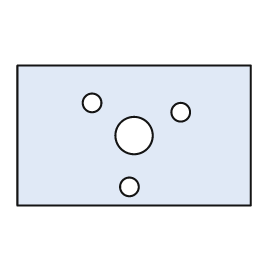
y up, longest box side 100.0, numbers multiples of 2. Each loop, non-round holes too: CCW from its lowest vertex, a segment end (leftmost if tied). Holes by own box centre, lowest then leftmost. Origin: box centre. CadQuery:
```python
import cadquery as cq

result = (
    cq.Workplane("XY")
    .moveTo(-50.0, -30.0)
    .lineTo(50.0, -30.0)
    .lineTo(50.0, 30.0)
    .lineTo(-50.0, 30.0)
    .close()
    .moveTo(-2.0, -22.0)
    .circle(4.0)
    .moveTo(0.0, 0.0)
    .circle(8.0)
    .moveTo(20.0, 10.0)
    .circle(4.0)
    .moveTo(-18.0, 14.0)
    .circle(4.0)
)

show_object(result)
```